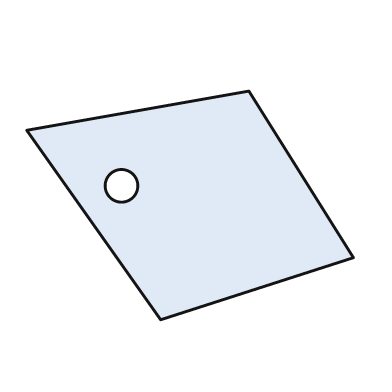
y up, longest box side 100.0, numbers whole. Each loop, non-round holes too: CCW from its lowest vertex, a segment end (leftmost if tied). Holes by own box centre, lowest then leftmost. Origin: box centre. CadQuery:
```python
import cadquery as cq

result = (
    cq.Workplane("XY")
    .moveTo(-9.0, -35.0)
    .lineTo(50.0, -16.0)
    .lineTo(18.0, 35.0)
    .lineTo(-50.0, 23.0)
    .close()
    .moveTo(-21.0, 6.0)
    .circle(5.0)
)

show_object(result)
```